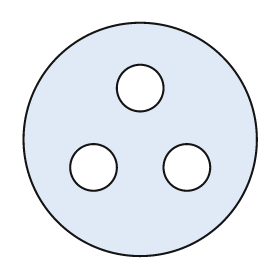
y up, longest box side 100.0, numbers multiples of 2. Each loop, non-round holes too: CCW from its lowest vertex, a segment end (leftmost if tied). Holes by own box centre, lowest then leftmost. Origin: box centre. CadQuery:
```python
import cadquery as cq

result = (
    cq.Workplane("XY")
    .moveTo(0.0, 0.0)
    .circle(50.0)
    .moveTo(-20.0, -12.0)
    .circle(10.0)
    .moveTo(20.0, -12.0)
    .circle(10.0)
    .moveTo(0.0, 22.0)
    .circle(10.0)
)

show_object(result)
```